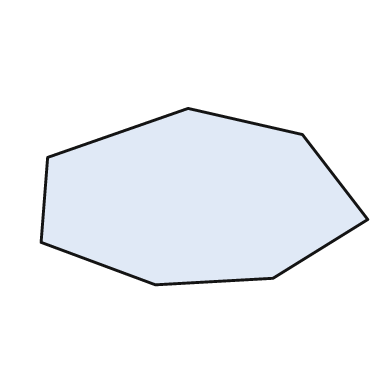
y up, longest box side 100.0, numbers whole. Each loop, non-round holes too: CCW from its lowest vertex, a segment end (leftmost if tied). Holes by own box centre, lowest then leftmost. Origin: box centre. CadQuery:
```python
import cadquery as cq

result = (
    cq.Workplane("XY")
    .moveTo(-15.0, -27.0)
    .lineTo(21.0, -25.0)
    .lineTo(50.0, -7.0)
    .lineTo(30.0, 19.0)
    .lineTo(-5.0, 27.0)
    .lineTo(-48.0, 12.0)
    .lineTo(-50.0, -14.0)
    .close()
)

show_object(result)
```